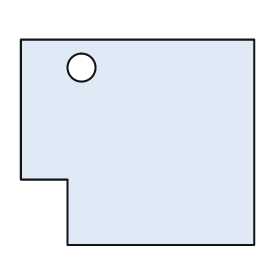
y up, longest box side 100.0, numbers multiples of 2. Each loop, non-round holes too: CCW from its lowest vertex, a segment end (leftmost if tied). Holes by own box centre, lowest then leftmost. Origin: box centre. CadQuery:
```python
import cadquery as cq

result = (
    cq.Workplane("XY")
    .moveTo(-30.0, -44.0)
    .lineTo(50.0, -44.0)
    .lineTo(50.0, 44.0)
    .lineTo(-50.0, 44.0)
    .lineTo(-50.0, -16.0)
    .lineTo(-30.0, -16.0)
    .close()
    .moveTo(-24.0, 32.0)
    .circle(6.0)
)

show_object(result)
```